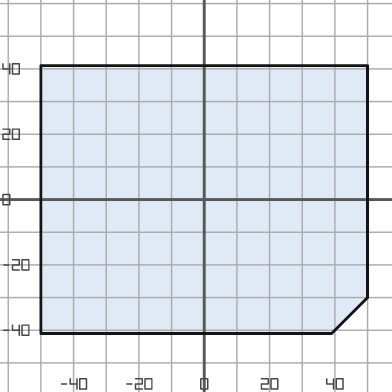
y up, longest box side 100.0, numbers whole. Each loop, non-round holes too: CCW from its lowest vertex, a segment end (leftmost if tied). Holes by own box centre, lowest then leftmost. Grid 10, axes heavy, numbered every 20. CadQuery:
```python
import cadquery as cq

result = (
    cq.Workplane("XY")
    .moveTo(-50.0, -41.0)
    .lineTo(39.0, -41.0)
    .lineTo(50.0, -30.0)
    .lineTo(50.0, 41.0)
    .lineTo(-50.0, 41.0)
    .close()
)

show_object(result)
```